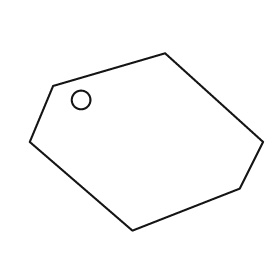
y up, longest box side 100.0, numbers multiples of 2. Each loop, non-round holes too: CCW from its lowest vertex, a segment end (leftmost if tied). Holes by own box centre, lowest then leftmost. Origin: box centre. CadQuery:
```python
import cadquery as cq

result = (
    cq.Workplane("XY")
    .moveTo(-6.0, -38.0)
    .lineTo(40.0, -20.0)
    .lineTo(50.0, 0.0)
    .lineTo(8.0, 38.0)
    .lineTo(-40.0, 24.0)
    .lineTo(-50.0, 0.0)
    .close()
    .moveTo(-28.0, 18.0)
    .circle(4.0)
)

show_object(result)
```